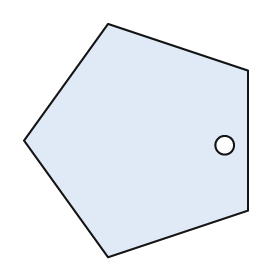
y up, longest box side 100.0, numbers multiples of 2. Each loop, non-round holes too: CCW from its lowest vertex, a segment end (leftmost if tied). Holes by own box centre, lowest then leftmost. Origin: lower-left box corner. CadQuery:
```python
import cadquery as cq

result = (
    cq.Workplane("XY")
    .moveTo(36.0, 0.0)
    .lineTo(96.0, 20.0)
    .lineTo(96.0, 80.0)
    .lineTo(36.0, 100.0)
    .lineTo(0.0, 50.0)
    .close()
    .moveTo(86.0, 48.0)
    .circle(4.0)
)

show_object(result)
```